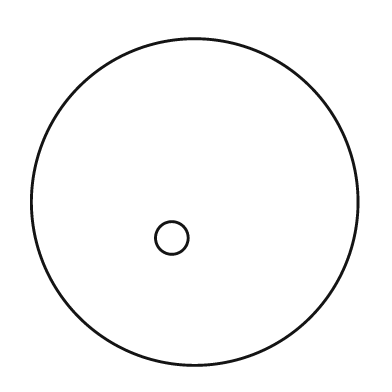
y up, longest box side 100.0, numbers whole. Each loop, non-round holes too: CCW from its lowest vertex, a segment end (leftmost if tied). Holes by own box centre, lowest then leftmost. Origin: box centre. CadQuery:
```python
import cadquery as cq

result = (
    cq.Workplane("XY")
    .moveTo(0.0, 0.0)
    .circle(50.0)
    .moveTo(-7.0, -11.0)
    .circle(5.0)
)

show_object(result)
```